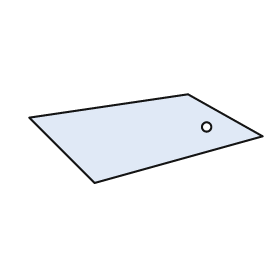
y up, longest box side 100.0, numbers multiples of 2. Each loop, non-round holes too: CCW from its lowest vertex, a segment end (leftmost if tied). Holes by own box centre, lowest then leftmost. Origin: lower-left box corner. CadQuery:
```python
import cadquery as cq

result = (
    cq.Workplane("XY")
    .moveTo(28.0, 0.0)
    .lineTo(100.0, 20.0)
    .lineTo(68.0, 38.0)
    .lineTo(0.0, 28.0)
    .close()
    .moveTo(76.0, 24.0)
    .circle(2.0)
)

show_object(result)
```